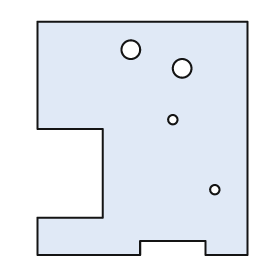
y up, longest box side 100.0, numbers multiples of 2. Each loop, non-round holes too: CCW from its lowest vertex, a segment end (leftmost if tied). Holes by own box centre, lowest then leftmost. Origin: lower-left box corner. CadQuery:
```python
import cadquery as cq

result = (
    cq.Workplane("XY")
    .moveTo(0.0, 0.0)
    .lineTo(44.0, 0.0)
    .lineTo(44.0, 6.0)
    .lineTo(72.0, 6.0)
    .lineTo(72.0, 0.0)
    .lineTo(90.0, 0.0)
    .lineTo(90.0, 100.0)
    .lineTo(0.0, 100.0)
    .lineTo(0.0, 54.0)
    .lineTo(28.0, 54.0)
    .lineTo(28.0, 16.0)
    .lineTo(0.0, 16.0)
    .close()
    .moveTo(76.0, 28.0)
    .circle(2.0)
    .moveTo(58.0, 58.0)
    .circle(2.0)
    .moveTo(62.0, 80.0)
    .circle(4.0)
    .moveTo(40.0, 88.0)
    .circle(4.0)
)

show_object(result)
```